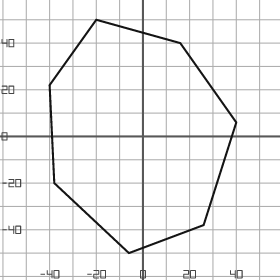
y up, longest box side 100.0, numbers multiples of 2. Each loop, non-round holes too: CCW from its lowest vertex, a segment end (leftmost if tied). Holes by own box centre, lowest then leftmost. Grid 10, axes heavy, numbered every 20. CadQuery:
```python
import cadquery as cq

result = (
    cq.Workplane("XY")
    .moveTo(-6.0, -50.0)
    .lineTo(26.0, -38.0)
    .lineTo(40.0, 6.0)
    .lineTo(16.0, 40.0)
    .lineTo(-20.0, 50.0)
    .lineTo(-40.0, 22.0)
    .lineTo(-38.0, -20.0)
    .close()
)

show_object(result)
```